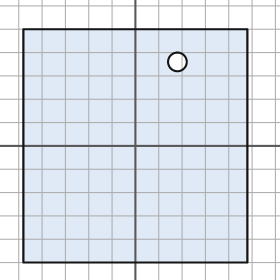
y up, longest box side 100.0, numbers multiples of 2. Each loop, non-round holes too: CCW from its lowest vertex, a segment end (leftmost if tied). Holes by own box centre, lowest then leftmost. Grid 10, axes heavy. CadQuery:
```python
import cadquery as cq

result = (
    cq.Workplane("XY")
    .moveTo(-48.0, -50.0)
    .lineTo(48.0, -50.0)
    .lineTo(48.0, 50.0)
    .lineTo(-48.0, 50.0)
    .close()
    .moveTo(18.0, 36.0)
    .circle(4.0)
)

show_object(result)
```